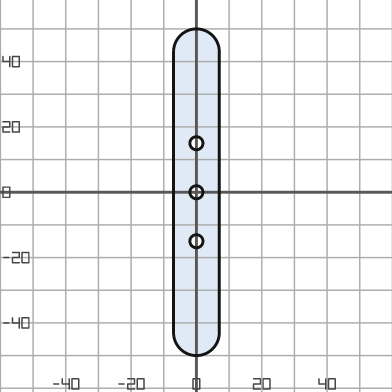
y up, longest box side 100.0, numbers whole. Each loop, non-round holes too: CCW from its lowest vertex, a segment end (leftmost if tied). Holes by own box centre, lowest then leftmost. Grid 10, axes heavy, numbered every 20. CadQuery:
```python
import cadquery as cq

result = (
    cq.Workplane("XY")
    .moveTo(-7.0, -43.0)
    .threePointArc((0.0, -50.0), (7.0, -43.0))
    .lineTo(7.0, 43.0)
    .threePointArc((0.0, 50.0), (-7.0, 43.0))
    .close()
    .moveTo(0.0, -15.0)
    .circle(2.0)
    .moveTo(0.0, 0.0)
    .circle(2.0)
    .moveTo(0.0, 15.0)
    .circle(2.0)
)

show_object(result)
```